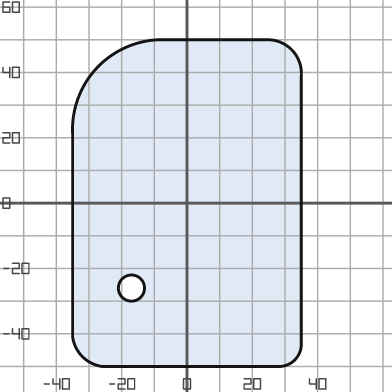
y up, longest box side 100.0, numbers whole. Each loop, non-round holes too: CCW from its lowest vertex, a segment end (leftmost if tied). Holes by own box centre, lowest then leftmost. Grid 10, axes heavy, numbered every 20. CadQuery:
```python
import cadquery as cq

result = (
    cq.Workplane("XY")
    .moveTo(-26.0, -50.0)
    .lineTo(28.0, -50.0)
    .threePointArc((33.0, -48.0), (35.0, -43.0))
    .lineTo(35.0, 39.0)
    .threePointArc((32.0, 47.0), (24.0, 50.0))
    .lineTo(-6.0, 50.0)
    .threePointArc((-27.0, 42.0), (-35.0, 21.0))
    .lineTo(-35.0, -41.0)
    .threePointArc((-32.0, -47.0), (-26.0, -50.0))
    .close()
    .moveTo(-17.0, -26.0)
    .circle(4.0)
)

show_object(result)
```